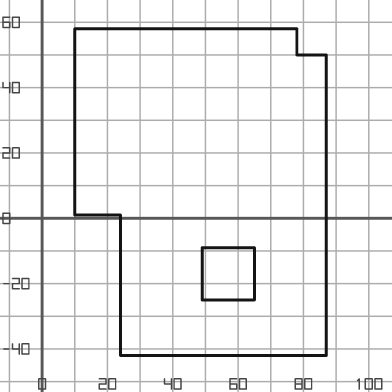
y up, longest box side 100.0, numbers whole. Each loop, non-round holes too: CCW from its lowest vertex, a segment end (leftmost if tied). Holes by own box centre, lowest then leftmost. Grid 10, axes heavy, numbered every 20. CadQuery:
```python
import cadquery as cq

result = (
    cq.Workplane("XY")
    .moveTo(24.0, -42.0)
    .lineTo(87.0, -42.0)
    .lineTo(87.0, 50.0)
    .lineTo(78.0, 50.0)
    .lineTo(78.0, 58.0)
    .lineTo(10.0, 58.0)
    .lineTo(10.0, 1.0)
    .lineTo(24.0, 1.0)
    .close()
    .moveTo(49.0, -25.0)
    .lineTo(65.0, -25.0)
    .lineTo(65.0, -9.0)
    .lineTo(49.0, -9.0)
    .close()
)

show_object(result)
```